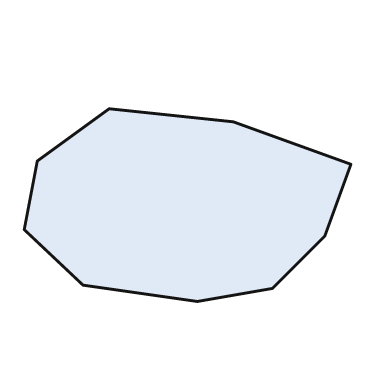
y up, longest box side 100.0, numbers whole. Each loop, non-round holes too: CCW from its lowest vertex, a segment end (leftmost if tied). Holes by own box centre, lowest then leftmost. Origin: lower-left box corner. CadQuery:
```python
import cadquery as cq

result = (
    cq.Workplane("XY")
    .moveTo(53.0, 0.0)
    .lineTo(76.0, 4.0)
    .lineTo(92.0, 20.0)
    .lineTo(100.0, 42.0)
    .lineTo(64.0, 55.0)
    .lineTo(26.0, 59.0)
    .lineTo(4.0, 43.0)
    .lineTo(0.0, 22.0)
    .lineTo(18.0, 5.0)
    .close()
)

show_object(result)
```